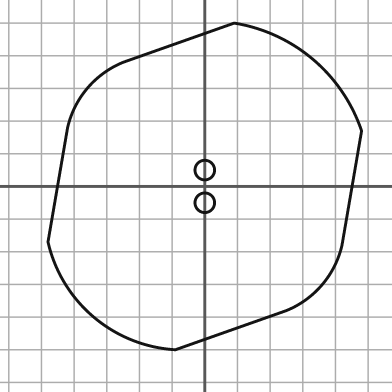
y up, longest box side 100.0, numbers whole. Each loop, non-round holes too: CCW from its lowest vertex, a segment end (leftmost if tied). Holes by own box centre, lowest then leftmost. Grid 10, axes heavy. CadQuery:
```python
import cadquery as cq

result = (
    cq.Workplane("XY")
    .moveTo(-9.0, -50.0)
    .lineTo(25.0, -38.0)
    .threePointArc((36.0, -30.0), (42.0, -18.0))
    .lineTo(48.0, 17.0)
    .threePointArc((33.0, 39.0), (9.0, 50.0))
    .lineTo(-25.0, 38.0)
    .threePointArc((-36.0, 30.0), (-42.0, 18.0))
    .lineTo(-48.0, -17.0)
    .threePointArc((-34.0, -40.0), (-9.0, -50.0))
    .close()
    .moveTo(0.0, -5.0)
    .circle(3.0)
    .moveTo(0.0, 5.0)
    .circle(3.0)
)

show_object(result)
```